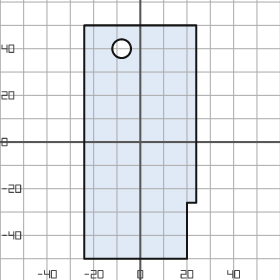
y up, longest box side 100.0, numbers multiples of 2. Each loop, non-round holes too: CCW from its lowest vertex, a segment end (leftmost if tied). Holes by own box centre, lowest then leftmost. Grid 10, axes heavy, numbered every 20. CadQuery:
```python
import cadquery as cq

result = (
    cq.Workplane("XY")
    .moveTo(-24.0, -50.0)
    .lineTo(20.0, -50.0)
    .lineTo(20.0, -26.0)
    .lineTo(24.0, -26.0)
    .lineTo(24.0, 50.0)
    .lineTo(-24.0, 50.0)
    .close()
    .moveTo(-8.0, 40.0)
    .circle(4.0)
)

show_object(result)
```